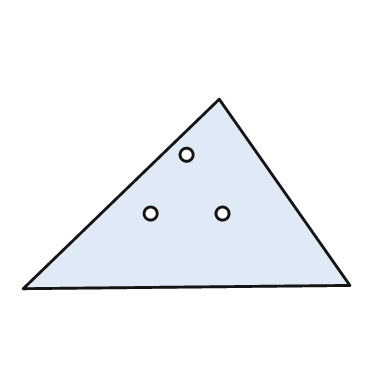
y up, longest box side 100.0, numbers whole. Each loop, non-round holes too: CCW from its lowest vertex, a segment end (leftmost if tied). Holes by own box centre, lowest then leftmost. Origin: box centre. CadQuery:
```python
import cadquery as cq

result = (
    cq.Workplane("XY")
    .moveTo(-50.0, -29.0)
    .lineTo(50.0, -28.0)
    .lineTo(10.0, 29.0)
    .close()
    .moveTo(-11.0, -6.0)
    .circle(2.0)
    .moveTo(11.0, -6.0)
    .circle(2.0)
    .moveTo(0.0, 12.0)
    .circle(2.0)
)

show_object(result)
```